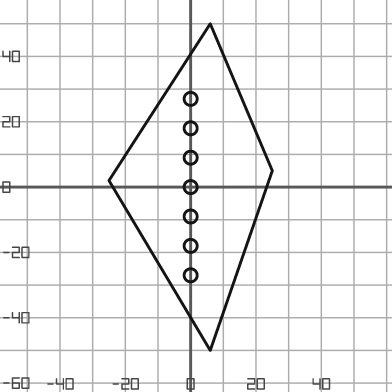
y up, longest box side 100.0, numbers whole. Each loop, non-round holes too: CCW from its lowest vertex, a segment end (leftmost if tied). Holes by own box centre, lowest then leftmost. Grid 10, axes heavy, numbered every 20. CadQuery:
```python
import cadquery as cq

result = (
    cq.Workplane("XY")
    .moveTo(6.0, -50.0)
    .lineTo(25.0, 5.0)
    .lineTo(6.0, 50.0)
    .lineTo(-25.0, 2.0)
    .close()
    .moveTo(0.0, -27.0)
    .circle(2.0)
    .moveTo(0.0, -18.0)
    .circle(2.0)
    .moveTo(0.0, -9.0)
    .circle(2.0)
    .moveTo(0.0, 0.0)
    .circle(2.0)
    .moveTo(0.0, 9.0)
    .circle(2.0)
    .moveTo(0.0, 18.0)
    .circle(2.0)
    .moveTo(0.0, 27.0)
    .circle(2.0)
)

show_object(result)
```